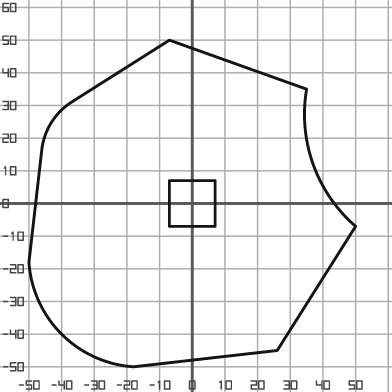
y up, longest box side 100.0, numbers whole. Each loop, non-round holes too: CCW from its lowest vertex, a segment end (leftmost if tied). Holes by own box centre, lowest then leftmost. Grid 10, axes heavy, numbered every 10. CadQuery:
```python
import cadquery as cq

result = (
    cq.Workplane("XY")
    .moveTo(-18.0, -50.0)
    .lineTo(26.0, -45.0)
    .lineTo(50.0, -7.0)
    .threePointArc((37.0, 12.0), (35.0, 35.0))
    .lineTo(-7.0, 50.0)
    .lineTo(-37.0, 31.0)
    .threePointArc((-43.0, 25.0), (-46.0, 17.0))
    .lineTo(-50.0, -18.0)
    .threePointArc((-40.0, -40.0), (-18.0, -50.0))
    .close()
    .moveTo(-7.0, -7.0)
    .lineTo(7.0, -7.0)
    .lineTo(7.0, 7.0)
    .lineTo(-7.0, 7.0)
    .close()
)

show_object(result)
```